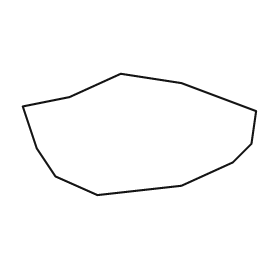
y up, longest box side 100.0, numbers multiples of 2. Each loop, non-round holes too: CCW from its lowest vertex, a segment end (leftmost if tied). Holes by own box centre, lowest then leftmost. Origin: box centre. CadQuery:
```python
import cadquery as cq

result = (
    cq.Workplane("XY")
    .moveTo(-18.0, -26.0)
    .lineTo(18.0, -22.0)
    .lineTo(40.0, -12.0)
    .lineTo(48.0, -4.0)
    .lineTo(50.0, 10.0)
    .lineTo(18.0, 22.0)
    .lineTo(-8.0, 26.0)
    .lineTo(-30.0, 16.0)
    .lineTo(-50.0, 12.0)
    .lineTo(-44.0, -6.0)
    .lineTo(-36.0, -18.0)
    .close()
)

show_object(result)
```